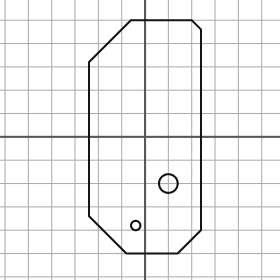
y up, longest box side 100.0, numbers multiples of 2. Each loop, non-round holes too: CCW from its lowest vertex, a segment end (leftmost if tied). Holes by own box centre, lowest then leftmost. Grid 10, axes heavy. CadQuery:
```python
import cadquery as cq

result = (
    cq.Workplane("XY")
    .moveTo(-8.0, -50.0)
    .lineTo(14.0, -50.0)
    .lineTo(24.0, -40.0)
    .lineTo(24.0, 46.0)
    .lineTo(20.0, 50.0)
    .lineTo(-6.0, 50.0)
    .lineTo(-24.0, 32.0)
    .lineTo(-24.0, -34.0)
    .close()
    .moveTo(-4.0, -38.0)
    .circle(2.0)
    .moveTo(10.0, -20.0)
    .circle(4.0)
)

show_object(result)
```